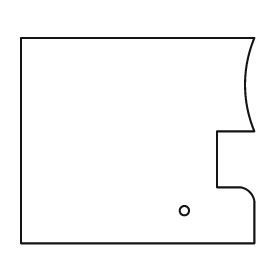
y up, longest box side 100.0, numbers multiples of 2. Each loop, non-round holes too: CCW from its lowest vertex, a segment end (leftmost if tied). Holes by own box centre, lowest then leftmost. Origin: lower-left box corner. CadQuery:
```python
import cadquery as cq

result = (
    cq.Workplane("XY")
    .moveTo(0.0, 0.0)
    .lineTo(100.0, 0.0)
    .lineTo(100.0, 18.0)
    .threePointArc((98.0, 22.0), (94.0, 24.0))
    .lineTo(84.0, 24.0)
    .lineTo(84.0, 48.0)
    .lineTo(100.0, 48.0)
    .threePointArc((96.0, 68.0), (100.0, 88.0))
    .lineTo(0.0, 88.0)
    .close()
    .moveTo(70.0, 14.0)
    .circle(2.0)
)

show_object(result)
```